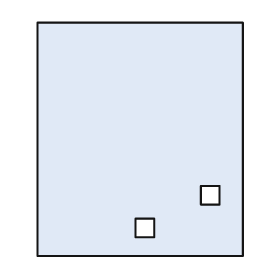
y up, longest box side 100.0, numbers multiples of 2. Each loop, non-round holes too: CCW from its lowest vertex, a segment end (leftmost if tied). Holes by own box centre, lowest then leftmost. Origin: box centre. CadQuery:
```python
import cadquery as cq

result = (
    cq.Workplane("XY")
    .moveTo(-44.0, -50.0)
    .lineTo(44.0, -50.0)
    .lineTo(44.0, 50.0)
    .lineTo(-44.0, 50.0)
    .close()
    .moveTo(-2.0, -42.0)
    .lineTo(6.0, -42.0)
    .lineTo(6.0, -34.0)
    .lineTo(-2.0, -34.0)
    .close()
    .moveTo(26.0, -28.0)
    .lineTo(34.0, -28.0)
    .lineTo(34.0, -20.0)
    .lineTo(26.0, -20.0)
    .close()
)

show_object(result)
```